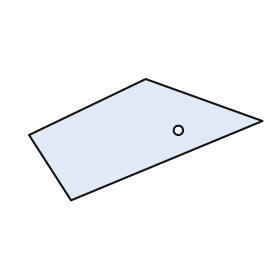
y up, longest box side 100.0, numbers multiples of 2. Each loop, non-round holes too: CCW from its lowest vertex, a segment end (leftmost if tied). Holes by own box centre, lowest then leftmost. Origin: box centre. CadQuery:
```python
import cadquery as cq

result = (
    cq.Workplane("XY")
    .moveTo(-32.0, -26.0)
    .lineTo(50.0, 8.0)
    .lineTo(0.0, 26.0)
    .lineTo(-50.0, 2.0)
    .close()
    .moveTo(14.0, 4.0)
    .circle(2.0)
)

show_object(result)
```